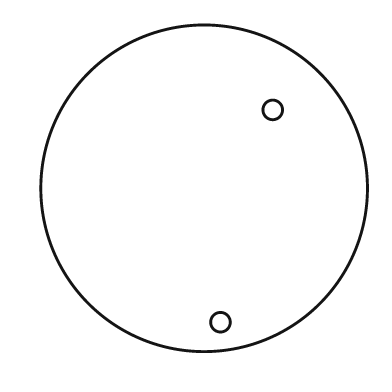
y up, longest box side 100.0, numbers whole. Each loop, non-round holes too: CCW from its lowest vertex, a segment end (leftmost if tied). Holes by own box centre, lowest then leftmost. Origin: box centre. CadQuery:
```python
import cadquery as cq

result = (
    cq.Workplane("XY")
    .moveTo(0.0, 0.0)
    .circle(50.0)
    .moveTo(5.0, -41.0)
    .circle(3.0)
    .moveTo(21.0, 24.0)
    .circle(3.0)
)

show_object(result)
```